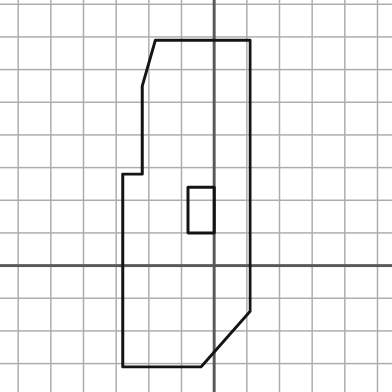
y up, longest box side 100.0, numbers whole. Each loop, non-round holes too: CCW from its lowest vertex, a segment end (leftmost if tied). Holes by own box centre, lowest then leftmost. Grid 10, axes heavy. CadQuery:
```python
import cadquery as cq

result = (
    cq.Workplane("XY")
    .moveTo(-28.0, -31.0)
    .lineTo(-4.0, -31.0)
    .lineTo(11.0, -14.0)
    .lineTo(11.0, 69.0)
    .lineTo(-18.0, 69.0)
    .lineTo(-22.0, 55.0)
    .lineTo(-22.0, 28.0)
    .lineTo(-28.0, 28.0)
    .close()
    .moveTo(-8.0, 10.0)
    .lineTo(0.0, 10.0)
    .lineTo(0.0, 24.0)
    .lineTo(-8.0, 24.0)
    .close()
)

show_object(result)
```